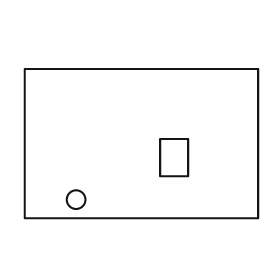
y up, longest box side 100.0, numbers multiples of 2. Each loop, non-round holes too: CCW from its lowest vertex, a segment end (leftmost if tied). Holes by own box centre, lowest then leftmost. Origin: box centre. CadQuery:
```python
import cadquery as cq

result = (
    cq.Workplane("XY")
    .moveTo(-50.0, -32.0)
    .lineTo(50.0, -32.0)
    .lineTo(50.0, 32.0)
    .lineTo(-50.0, 32.0)
    .close()
    .moveTo(-28.0, -24.0)
    .circle(4.0)
    .moveTo(8.0, -14.0)
    .lineTo(20.0, -14.0)
    .lineTo(20.0, 2.0)
    .lineTo(8.0, 2.0)
    .close()
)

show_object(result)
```